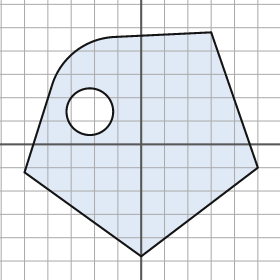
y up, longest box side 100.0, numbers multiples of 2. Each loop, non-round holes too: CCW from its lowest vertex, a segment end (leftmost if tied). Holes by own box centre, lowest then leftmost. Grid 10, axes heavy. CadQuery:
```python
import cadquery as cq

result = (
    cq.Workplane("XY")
    .moveTo(0.0, -48.0)
    .lineTo(50.0, -10.0)
    .lineTo(30.0, 48.0)
    .lineTo(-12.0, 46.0)
    .threePointArc((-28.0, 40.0), (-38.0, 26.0))
    .lineTo(-50.0, -12.0)
    .close()
    .moveTo(-22.0, 14.0)
    .circle(10.0)
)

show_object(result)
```